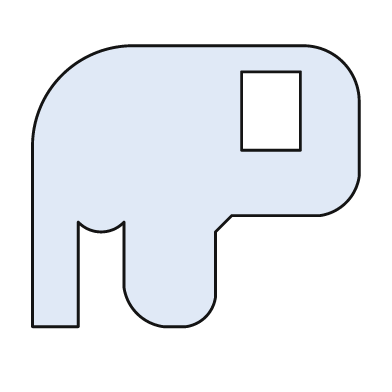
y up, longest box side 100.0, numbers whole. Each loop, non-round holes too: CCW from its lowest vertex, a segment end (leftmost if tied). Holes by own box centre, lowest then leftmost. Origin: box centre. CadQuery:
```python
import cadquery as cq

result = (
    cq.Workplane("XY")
    .moveTo(-50.0, -43.0)
    .lineTo(-36.0, -43.0)
    .lineTo(-36.0, -11.0)
    .threePointArc((-29.0, -14.0), (-22.0, -11.0))
    .lineTo(-22.0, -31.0)
    .threePointArc((-18.0, -39.0), (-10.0, -43.0))
    .lineTo(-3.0, -43.0)
    .threePointArc((3.0, -40.0), (6.0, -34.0))
    .lineTo(6.0, -14.0)
    .lineTo(11.0, -9.0)
    .lineTo(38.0, -9.0)
    .threePointArc((46.0, -5.0), (50.0, 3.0))
    .lineTo(50.0, 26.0)
    .threePointArc((45.0, 38.0), (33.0, 43.0))
    .lineTo(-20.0, 43.0)
    .threePointArc((-41.0, 34.0), (-50.0, 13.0))
    .close()
    .moveTo(14.0, 11.0)
    .lineTo(32.0, 11.0)
    .lineTo(32.0, 35.0)
    .lineTo(14.0, 35.0)
    .close()
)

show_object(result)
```